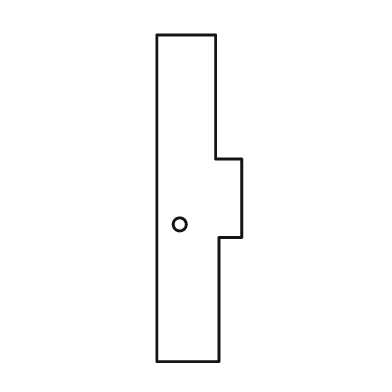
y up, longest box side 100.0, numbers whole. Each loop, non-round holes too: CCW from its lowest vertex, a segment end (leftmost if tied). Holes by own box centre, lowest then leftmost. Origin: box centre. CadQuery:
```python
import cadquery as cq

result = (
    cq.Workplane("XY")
    .moveTo(-13.0, -50.0)
    .lineTo(6.0, -50.0)
    .lineTo(6.0, -12.0)
    .lineTo(13.0, -12.0)
    .lineTo(13.0, 12.0)
    .lineTo(5.0, 12.0)
    .lineTo(5.0, 50.0)
    .lineTo(-13.0, 50.0)
    .close()
    .moveTo(-6.0, -8.0)
    .circle(2.0)
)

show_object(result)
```